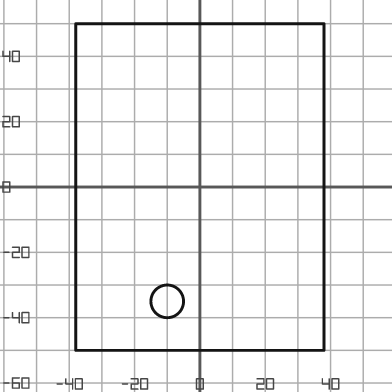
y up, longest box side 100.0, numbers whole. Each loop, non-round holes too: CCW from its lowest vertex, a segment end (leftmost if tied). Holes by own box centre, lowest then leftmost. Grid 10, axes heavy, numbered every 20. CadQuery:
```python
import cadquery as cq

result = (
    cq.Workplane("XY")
    .moveTo(-38.0, -50.0)
    .lineTo(38.0, -50.0)
    .lineTo(38.0, 50.0)
    .lineTo(-38.0, 50.0)
    .close()
    .moveTo(-10.0, -35.0)
    .circle(5.0)
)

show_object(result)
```